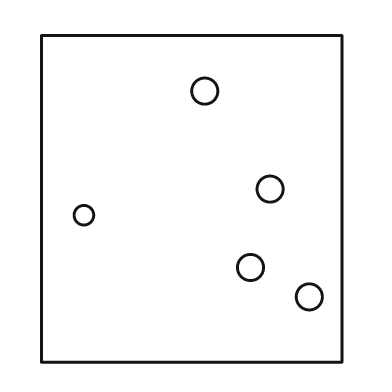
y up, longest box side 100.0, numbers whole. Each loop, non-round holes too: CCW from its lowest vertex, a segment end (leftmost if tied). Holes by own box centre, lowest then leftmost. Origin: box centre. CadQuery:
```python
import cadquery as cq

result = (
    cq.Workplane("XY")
    .moveTo(-46.0, -50.0)
    .lineTo(46.0, -50.0)
    .lineTo(46.0, 50.0)
    .lineTo(-46.0, 50.0)
    .close()
    .moveTo(36.0, -30.0)
    .circle(4.0)
    .moveTo(18.0, -21.0)
    .circle(4.0)
    .moveTo(-33.0, -5.0)
    .circle(3.0)
    .moveTo(24.0, 3.0)
    .circle(4.0)
    .moveTo(4.0, 33.0)
    .circle(4.0)
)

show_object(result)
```